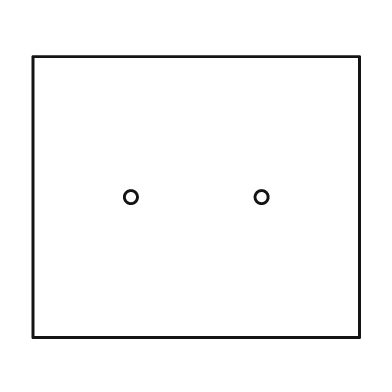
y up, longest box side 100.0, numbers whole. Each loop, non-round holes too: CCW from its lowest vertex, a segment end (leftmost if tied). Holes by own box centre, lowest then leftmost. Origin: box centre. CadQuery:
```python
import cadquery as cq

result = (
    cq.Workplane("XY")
    .moveTo(-50.0, -43.0)
    .lineTo(50.0, -43.0)
    .lineTo(50.0, 43.0)
    .lineTo(-50.0, 43.0)
    .close()
    .moveTo(-20.0, 0.0)
    .circle(2.0)
    .moveTo(20.0, 0.0)
    .circle(2.0)
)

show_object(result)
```